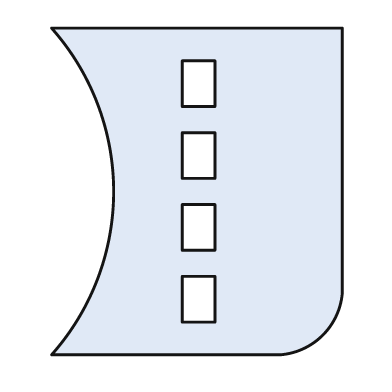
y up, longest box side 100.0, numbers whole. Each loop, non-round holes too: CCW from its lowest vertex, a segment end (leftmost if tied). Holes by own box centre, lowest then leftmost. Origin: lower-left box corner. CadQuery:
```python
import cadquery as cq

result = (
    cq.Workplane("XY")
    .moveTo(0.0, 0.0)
    .lineTo(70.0, 0.0)
    .threePointArc((83.0, 6.0), (89.0, 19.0))
    .lineTo(89.0, 100.0)
    .lineTo(0.0, 100.0)
    .threePointArc((19.0, 50.0), (0.0, 0.0))
    .close()
    .moveTo(40.0, 10.0)
    .lineTo(50.0, 10.0)
    .lineTo(50.0, 24.0)
    .lineTo(40.0, 24.0)
    .close()
    .moveTo(40.0, 32.0)
    .lineTo(50.0, 32.0)
    .lineTo(50.0, 46.0)
    .lineTo(40.0, 46.0)
    .close()
    .moveTo(40.0, 54.0)
    .lineTo(50.0, 54.0)
    .lineTo(50.0, 68.0)
    .lineTo(40.0, 68.0)
    .close()
    .moveTo(40.0, 76.0)
    .lineTo(50.0, 76.0)
    .lineTo(50.0, 90.0)
    .lineTo(40.0, 90.0)
    .close()
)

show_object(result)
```